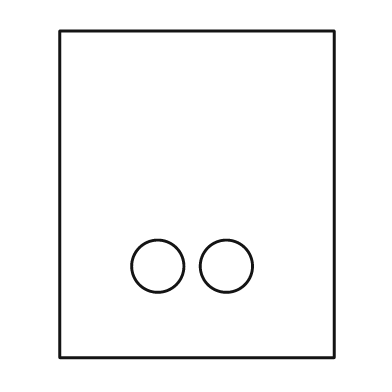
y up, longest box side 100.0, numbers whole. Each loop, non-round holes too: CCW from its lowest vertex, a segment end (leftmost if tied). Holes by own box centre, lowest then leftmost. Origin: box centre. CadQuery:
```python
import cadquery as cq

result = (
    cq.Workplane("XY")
    .moveTo(-42.0, -50.0)
    .lineTo(42.0, -50.0)
    .lineTo(42.0, 50.0)
    .lineTo(-42.0, 50.0)
    .close()
    .moveTo(-12.0, -22.0)
    .circle(8.0)
    .moveTo(9.0, -22.0)
    .circle(8.0)
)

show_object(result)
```